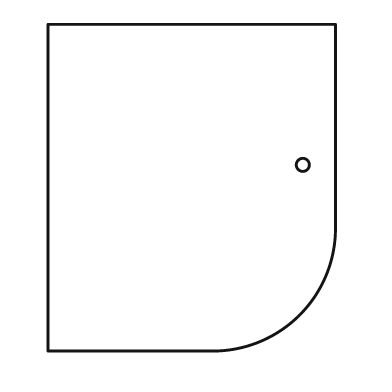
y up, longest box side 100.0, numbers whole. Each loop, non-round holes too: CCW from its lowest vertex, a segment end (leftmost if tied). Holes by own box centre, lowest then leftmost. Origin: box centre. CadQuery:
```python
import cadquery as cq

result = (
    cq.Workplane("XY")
    .moveTo(-44.0, -50.0)
    .lineTo(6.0, -50.0)
    .threePointArc((33.0, -39.0), (44.0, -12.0))
    .lineTo(44.0, 50.0)
    .lineTo(-44.0, 50.0)
    .close()
    .moveTo(34.0, 7.0)
    .circle(2.0)
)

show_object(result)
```